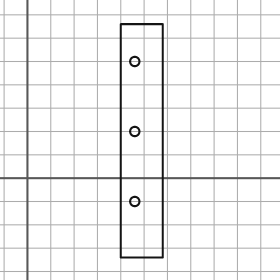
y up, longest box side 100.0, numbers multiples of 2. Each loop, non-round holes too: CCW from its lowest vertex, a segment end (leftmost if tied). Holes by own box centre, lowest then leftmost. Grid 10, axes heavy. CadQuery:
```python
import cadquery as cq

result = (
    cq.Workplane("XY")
    .moveTo(40.0, -34.0)
    .lineTo(58.0, -34.0)
    .lineTo(58.0, 66.0)
    .lineTo(40.0, 66.0)
    .close()
    .moveTo(46.0, -10.0)
    .circle(2.0)
    .moveTo(46.0, 20.0)
    .circle(2.0)
    .moveTo(46.0, 50.0)
    .circle(2.0)
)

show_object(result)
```